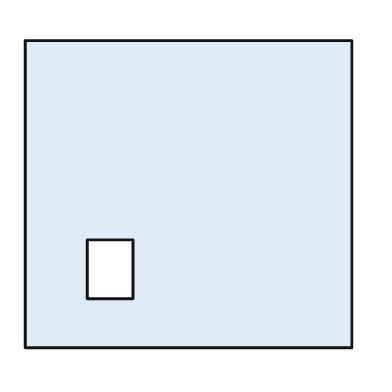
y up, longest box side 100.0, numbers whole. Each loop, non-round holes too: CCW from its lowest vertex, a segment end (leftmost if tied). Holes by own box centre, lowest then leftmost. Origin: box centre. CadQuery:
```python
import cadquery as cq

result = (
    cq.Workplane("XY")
    .moveTo(-50.0, -47.0)
    .lineTo(50.0, -47.0)
    .lineTo(50.0, 47.0)
    .lineTo(-50.0, 47.0)
    .close()
    .moveTo(-31.0, -32.0)
    .lineTo(-17.0, -32.0)
    .lineTo(-17.0, -14.0)
    .lineTo(-31.0, -14.0)
    .close()
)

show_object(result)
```